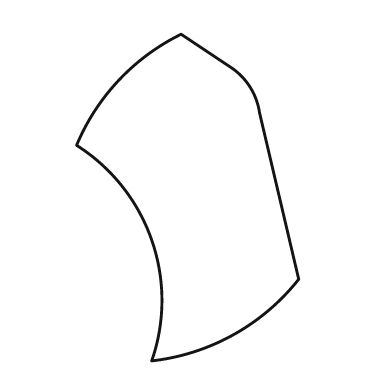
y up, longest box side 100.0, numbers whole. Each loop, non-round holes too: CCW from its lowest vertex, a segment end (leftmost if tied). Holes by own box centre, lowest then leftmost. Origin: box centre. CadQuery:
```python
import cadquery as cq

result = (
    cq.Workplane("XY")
    .moveTo(-11.0, -50.0)
    .threePointArc((14.0, -42.0), (34.0, -25.0))
    .lineTo(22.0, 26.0)
    .threePointArc((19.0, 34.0), (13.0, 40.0))
    .lineTo(-2.0, 50.0)
    .threePointArc((-21.0, 36.0), (-34.0, 16.0))
    .threePointArc((-11.0, -13.0), (-11.0, -50.0))
    .close()
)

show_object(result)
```